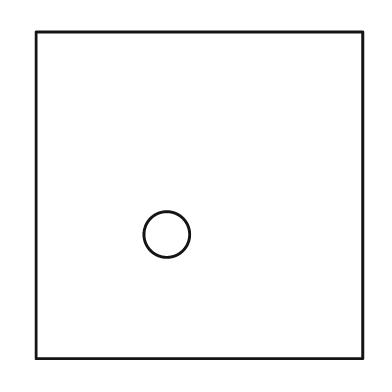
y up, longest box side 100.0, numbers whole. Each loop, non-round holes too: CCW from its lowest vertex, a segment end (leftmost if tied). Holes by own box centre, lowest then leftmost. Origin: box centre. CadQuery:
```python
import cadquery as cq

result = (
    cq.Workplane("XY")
    .moveTo(-50.0, -50.0)
    .lineTo(50.0, -50.0)
    .lineTo(50.0, 50.0)
    .lineTo(-50.0, 50.0)
    .close()
    .moveTo(-10.0, -12.0)
    .circle(7.0)
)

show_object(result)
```